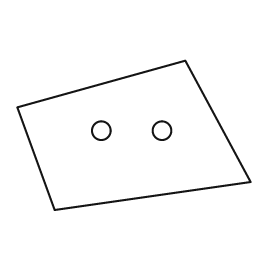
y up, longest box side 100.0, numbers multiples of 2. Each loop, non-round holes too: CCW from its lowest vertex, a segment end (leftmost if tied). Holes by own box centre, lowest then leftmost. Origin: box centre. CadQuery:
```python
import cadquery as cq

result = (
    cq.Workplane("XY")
    .moveTo(-34.0, -32.0)
    .lineTo(50.0, -20.0)
    .lineTo(22.0, 32.0)
    .lineTo(-50.0, 12.0)
    .close()
    .moveTo(-14.0, 2.0)
    .circle(4.0)
    .moveTo(12.0, 2.0)
    .circle(4.0)
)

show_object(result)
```